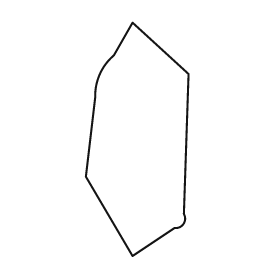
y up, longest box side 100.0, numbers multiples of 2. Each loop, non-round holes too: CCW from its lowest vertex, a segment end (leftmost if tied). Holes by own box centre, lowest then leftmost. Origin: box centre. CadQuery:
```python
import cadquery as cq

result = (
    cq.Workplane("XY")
    .moveTo(-2.0, -50.0)
    .lineTo(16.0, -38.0)
    .threePointArc((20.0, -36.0), (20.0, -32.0))
    .lineTo(22.0, 28.0)
    .lineTo(-2.0, 50.0)
    .lineTo(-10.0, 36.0)
    .threePointArc((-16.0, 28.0), (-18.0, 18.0))
    .lineTo(-22.0, -16.0)
    .close()
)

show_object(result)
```